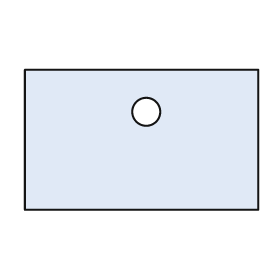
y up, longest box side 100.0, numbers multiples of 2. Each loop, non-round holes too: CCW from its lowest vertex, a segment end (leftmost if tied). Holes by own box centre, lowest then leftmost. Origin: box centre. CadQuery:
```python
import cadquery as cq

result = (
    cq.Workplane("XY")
    .moveTo(-50.0, -30.0)
    .lineTo(50.0, -30.0)
    .lineTo(50.0, 30.0)
    .lineTo(-50.0, 30.0)
    .close()
    .moveTo(2.0, 12.0)
    .circle(6.0)
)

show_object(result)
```